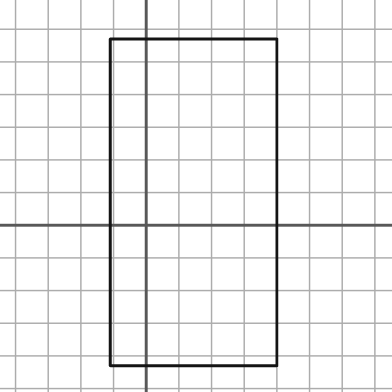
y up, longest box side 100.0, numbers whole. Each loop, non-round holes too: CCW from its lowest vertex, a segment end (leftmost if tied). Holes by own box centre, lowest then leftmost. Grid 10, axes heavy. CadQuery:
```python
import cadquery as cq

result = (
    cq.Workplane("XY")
    .moveTo(-11.0, -43.0)
    .lineTo(40.0, -43.0)
    .lineTo(40.0, 57.0)
    .lineTo(-11.0, 57.0)
    .close()
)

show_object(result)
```